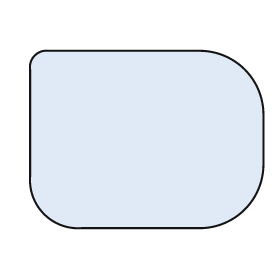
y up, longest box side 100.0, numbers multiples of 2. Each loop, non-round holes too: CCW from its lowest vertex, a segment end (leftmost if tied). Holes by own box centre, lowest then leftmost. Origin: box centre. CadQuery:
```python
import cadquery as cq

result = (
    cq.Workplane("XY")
    .moveTo(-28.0, -38.0)
    .lineTo(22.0, -38.0)
    .threePointArc((42.0, -30.0), (50.0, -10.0))
    .lineTo(50.0, 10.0)
    .threePointArc((42.0, 30.0), (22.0, 38.0))
    .lineTo(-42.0, 38.0)
    .threePointArc((-48.0, 36.0), (-50.0, 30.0))
    .lineTo(-50.0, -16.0)
    .threePointArc((-44.0, -32.0), (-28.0, -38.0))
    .close()
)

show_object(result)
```